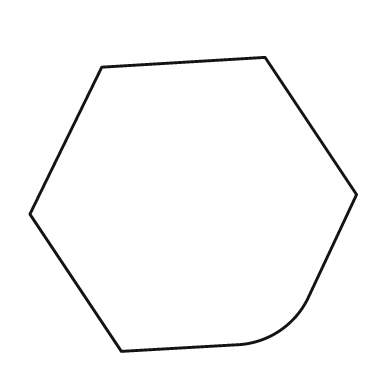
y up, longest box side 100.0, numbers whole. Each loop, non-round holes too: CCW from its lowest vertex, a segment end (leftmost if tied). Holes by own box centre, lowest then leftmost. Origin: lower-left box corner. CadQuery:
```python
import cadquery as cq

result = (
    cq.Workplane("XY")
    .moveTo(28.0, 0.0)
    .lineTo(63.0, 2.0)
    .threePointArc((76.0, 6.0), (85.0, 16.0))
    .lineTo(100.0, 48.0)
    .lineTo(72.0, 90.0)
    .lineTo(22.0, 87.0)
    .lineTo(0.0, 42.0)
    .close()
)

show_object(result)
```